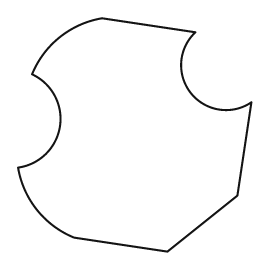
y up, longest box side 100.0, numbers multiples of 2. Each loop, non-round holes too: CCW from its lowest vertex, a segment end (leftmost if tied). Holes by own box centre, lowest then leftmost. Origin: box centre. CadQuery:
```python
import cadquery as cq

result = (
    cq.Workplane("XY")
    .moveTo(14.0, -50.0)
    .lineTo(44.0, -26.0)
    .lineTo(50.0, 14.0)
    .threePointArc((24.0, 18.0), (26.0, 44.0))
    .lineTo(-14.0, 50.0)
    .threePointArc((-32.0, 42.0), (-44.0, 26.0))
    .threePointArc((-32.0, 4.0), (-50.0, -14.0))
    .threePointArc((-42.0, -32.0), (-26.0, -44.0))
    .close()
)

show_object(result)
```